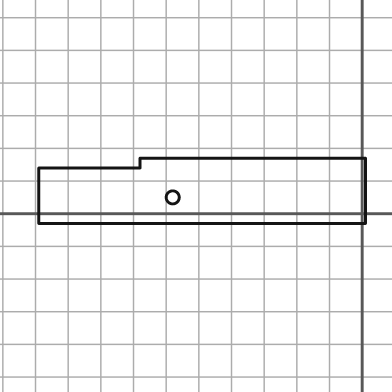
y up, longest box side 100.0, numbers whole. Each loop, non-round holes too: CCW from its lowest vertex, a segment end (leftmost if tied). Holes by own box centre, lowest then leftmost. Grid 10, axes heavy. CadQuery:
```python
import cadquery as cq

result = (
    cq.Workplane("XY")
    .moveTo(-99.0, -3.0)
    .lineTo(1.0, -3.0)
    .lineTo(1.0, 17.0)
    .lineTo(-68.0, 17.0)
    .lineTo(-68.0, 14.0)
    .lineTo(-99.0, 14.0)
    .close()
    .moveTo(-58.0, 5.0)
    .circle(2.0)
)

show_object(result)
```